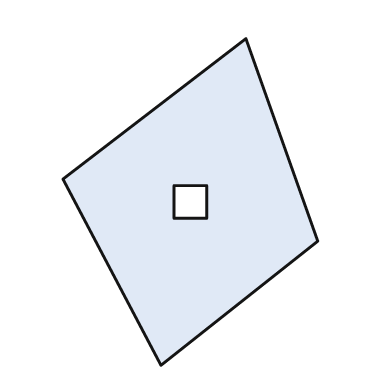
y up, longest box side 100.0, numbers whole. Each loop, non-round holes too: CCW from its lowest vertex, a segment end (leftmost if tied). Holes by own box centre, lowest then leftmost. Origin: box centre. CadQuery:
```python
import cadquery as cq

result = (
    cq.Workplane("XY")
    .moveTo(-9.0, -50.0)
    .lineTo(39.0, -12.0)
    .lineTo(17.0, 50.0)
    .lineTo(-39.0, 7.0)
    .close()
    .moveTo(-5.0, -5.0)
    .lineTo(5.0, -5.0)
    .lineTo(5.0, 5.0)
    .lineTo(-5.0, 5.0)
    .close()
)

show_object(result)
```